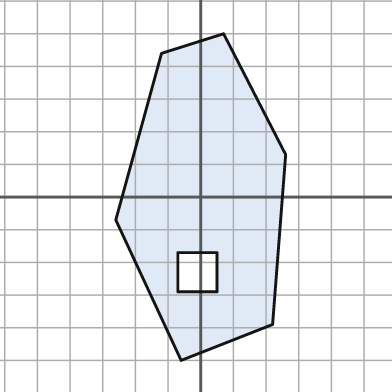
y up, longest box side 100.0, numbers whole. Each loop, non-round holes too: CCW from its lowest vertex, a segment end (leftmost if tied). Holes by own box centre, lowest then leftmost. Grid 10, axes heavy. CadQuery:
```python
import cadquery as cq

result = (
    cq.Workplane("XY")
    .moveTo(-6.0, -50.0)
    .lineTo(22.0, -39.0)
    .lineTo(26.0, 13.0)
    .lineTo(7.0, 50.0)
    .lineTo(-12.0, 44.0)
    .lineTo(-26.0, -7.0)
    .close()
    .moveTo(-7.0, -29.0)
    .lineTo(5.0, -29.0)
    .lineTo(5.0, -17.0)
    .lineTo(-7.0, -17.0)
    .close()
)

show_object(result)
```